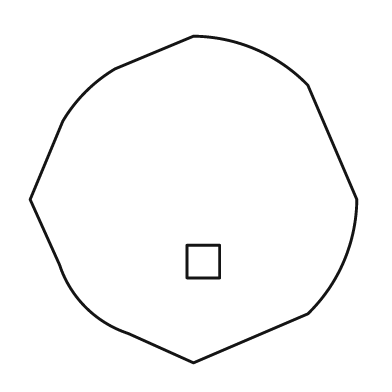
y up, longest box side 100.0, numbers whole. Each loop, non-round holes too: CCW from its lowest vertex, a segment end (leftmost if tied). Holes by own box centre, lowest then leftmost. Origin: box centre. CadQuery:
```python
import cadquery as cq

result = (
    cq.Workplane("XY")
    .moveTo(0.0, -50.0)
    .lineTo(35.0, -35.0)
    .threePointArc((46.0, -19.0), (50.0, 0.0))
    .lineTo(35.0, 35.0)
    .threePointArc((19.0, 46.0), (0.0, 50.0))
    .lineTo(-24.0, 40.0)
    .threePointArc((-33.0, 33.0), (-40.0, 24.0))
    .lineTo(-50.0, 0.0)
    .lineTo(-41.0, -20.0)
    .threePointArc((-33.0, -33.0), (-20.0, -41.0))
    .close()
    .moveTo(-2.0, -24.0)
    .lineTo(8.0, -24.0)
    .lineTo(8.0, -14.0)
    .lineTo(-2.0, -14.0)
    .close()
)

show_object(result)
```